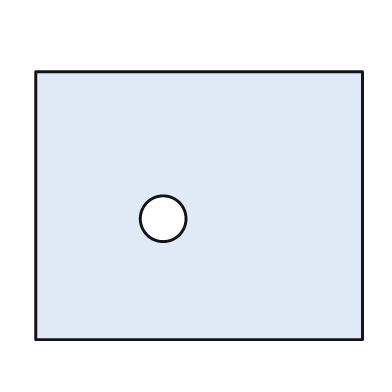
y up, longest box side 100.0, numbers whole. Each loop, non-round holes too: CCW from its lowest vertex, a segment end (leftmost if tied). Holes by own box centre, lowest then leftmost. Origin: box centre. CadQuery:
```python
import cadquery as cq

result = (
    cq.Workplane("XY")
    .moveTo(-50.0, -41.0)
    .lineTo(50.0, -41.0)
    .lineTo(50.0, 41.0)
    .lineTo(-50.0, 41.0)
    .close()
    .moveTo(-11.0, -4.0)
    .circle(7.0)
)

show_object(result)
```